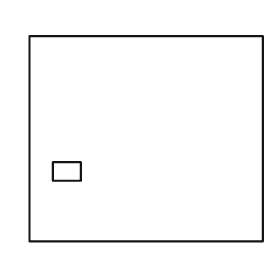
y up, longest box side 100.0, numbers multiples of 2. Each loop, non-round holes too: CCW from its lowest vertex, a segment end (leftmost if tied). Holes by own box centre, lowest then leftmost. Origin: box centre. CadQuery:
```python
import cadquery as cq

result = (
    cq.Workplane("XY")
    .moveTo(-50.0, -44.0)
    .lineTo(50.0, -44.0)
    .lineTo(50.0, 44.0)
    .lineTo(-50.0, 44.0)
    .close()
    .moveTo(-40.0, -18.0)
    .lineTo(-28.0, -18.0)
    .lineTo(-28.0, -10.0)
    .lineTo(-40.0, -10.0)
    .close()
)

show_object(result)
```